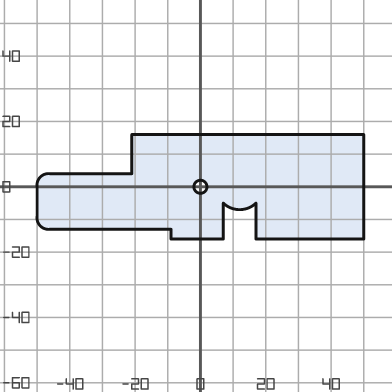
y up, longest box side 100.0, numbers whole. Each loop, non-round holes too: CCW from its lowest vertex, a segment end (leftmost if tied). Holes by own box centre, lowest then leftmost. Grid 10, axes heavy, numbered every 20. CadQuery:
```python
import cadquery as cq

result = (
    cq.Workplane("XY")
    .moveTo(-9.0, -16.0)
    .lineTo(7.0, -16.0)
    .lineTo(7.0, -5.0)
    .threePointArc((12.0, -7.0), (17.0, -5.0))
    .lineTo(17.0, -16.0)
    .lineTo(50.0, -16.0)
    .lineTo(50.0, 16.0)
    .lineTo(-21.0, 16.0)
    .lineTo(-21.0, 4.0)
    .lineTo(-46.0, 4.0)
    .threePointArc((-49.0, 3.0), (-50.0, 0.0))
    .lineTo(-50.0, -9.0)
    .threePointArc((-49.0, -12.0), (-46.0, -13.0))
    .lineTo(-9.0, -13.0)
    .close()
    .moveTo(0.0, 0.0)
    .circle(2.0)
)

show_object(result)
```